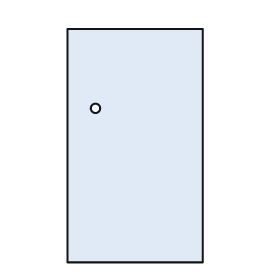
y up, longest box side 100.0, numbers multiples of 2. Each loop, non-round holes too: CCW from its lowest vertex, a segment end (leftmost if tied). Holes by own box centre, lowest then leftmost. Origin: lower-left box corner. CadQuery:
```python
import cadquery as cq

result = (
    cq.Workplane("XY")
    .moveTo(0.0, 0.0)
    .lineTo(58.0, 0.0)
    .lineTo(58.0, 100.0)
    .lineTo(0.0, 100.0)
    .close()
    .moveTo(12.0, 66.0)
    .circle(2.0)
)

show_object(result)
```